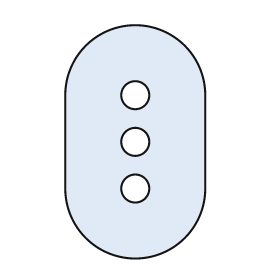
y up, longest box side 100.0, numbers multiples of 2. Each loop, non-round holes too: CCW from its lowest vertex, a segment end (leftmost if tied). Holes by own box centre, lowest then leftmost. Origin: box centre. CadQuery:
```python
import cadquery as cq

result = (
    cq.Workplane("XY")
    .moveTo(-30.0, -20.0)
    .threePointArc((0.0, -50.0), (30.0, -20.0))
    .lineTo(30.0, 20.0)
    .threePointArc((0.0, 50.0), (-30.0, 20.0))
    .close()
    .moveTo(0.0, -20.0)
    .circle(6.0)
    .moveTo(0.0, 0.0)
    .circle(6.0)
    .moveTo(0.0, 20.0)
    .circle(6.0)
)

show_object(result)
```